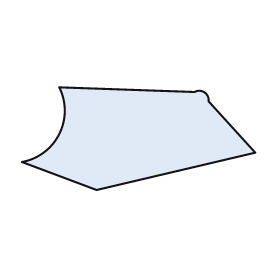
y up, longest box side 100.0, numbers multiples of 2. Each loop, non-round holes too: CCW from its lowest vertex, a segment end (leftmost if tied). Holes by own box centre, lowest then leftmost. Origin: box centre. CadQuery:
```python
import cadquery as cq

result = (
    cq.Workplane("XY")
    .moveTo(-18.0, -22.0)
    .lineTo(50.0, -6.0)
    .lineTo(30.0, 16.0)
    .threePointArc((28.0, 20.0), (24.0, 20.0))
    .lineTo(-34.0, 22.0)
    .threePointArc((-34.0, 2.0), (-50.0, -10.0))
    .close()
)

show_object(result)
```